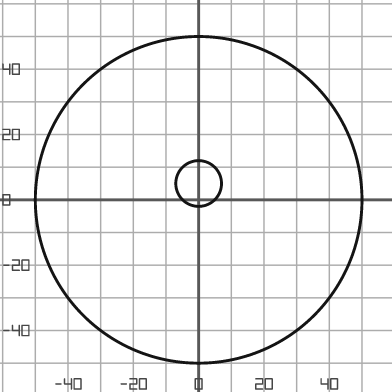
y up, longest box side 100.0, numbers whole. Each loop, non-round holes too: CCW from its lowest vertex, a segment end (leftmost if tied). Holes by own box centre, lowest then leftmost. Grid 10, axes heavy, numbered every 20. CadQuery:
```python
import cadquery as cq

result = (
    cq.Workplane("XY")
    .moveTo(0.0, 0.0)
    .circle(50.0)
    .moveTo(0.0, 5.0)
    .circle(7.0)
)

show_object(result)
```